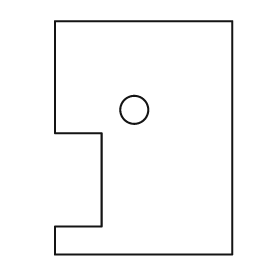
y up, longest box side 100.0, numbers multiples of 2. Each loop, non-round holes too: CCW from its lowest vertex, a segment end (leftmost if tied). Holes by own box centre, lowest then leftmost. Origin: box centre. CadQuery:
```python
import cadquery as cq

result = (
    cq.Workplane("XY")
    .moveTo(-38.0, -50.0)
    .lineTo(38.0, -50.0)
    .lineTo(38.0, 50.0)
    .lineTo(-38.0, 50.0)
    .lineTo(-38.0, 2.0)
    .lineTo(-18.0, 2.0)
    .lineTo(-18.0, -38.0)
    .lineTo(-38.0, -38.0)
    .close()
    .moveTo(-4.0, 12.0)
    .circle(6.0)
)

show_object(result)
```